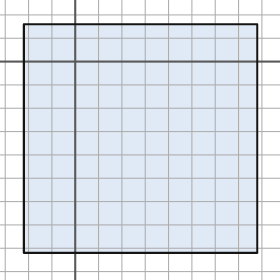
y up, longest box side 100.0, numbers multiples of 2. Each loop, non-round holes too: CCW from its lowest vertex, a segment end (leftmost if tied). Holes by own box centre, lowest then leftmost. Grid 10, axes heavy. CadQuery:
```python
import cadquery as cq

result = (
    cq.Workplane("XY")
    .moveTo(-22.0, -82.0)
    .lineTo(78.0, -82.0)
    .lineTo(78.0, 16.0)
    .lineTo(-22.0, 16.0)
    .close()
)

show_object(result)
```